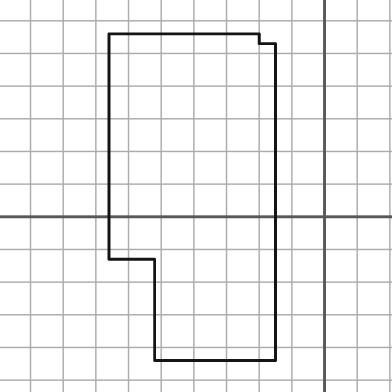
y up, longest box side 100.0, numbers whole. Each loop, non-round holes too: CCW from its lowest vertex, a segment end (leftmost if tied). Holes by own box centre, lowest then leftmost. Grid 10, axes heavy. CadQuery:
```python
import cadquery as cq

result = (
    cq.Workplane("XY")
    .moveTo(-52.0, -44.0)
    .lineTo(-15.0, -44.0)
    .lineTo(-15.0, 53.0)
    .lineTo(-20.0, 53.0)
    .lineTo(-20.0, 56.0)
    .lineTo(-66.0, 56.0)
    .lineTo(-66.0, -13.0)
    .lineTo(-52.0, -13.0)
    .close()
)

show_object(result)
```